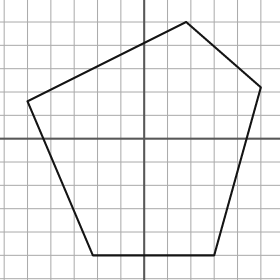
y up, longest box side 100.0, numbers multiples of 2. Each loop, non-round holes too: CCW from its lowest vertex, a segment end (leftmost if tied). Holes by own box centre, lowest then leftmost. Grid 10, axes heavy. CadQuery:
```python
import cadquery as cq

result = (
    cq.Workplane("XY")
    .moveTo(-22.0, -50.0)
    .lineTo(30.0, -50.0)
    .lineTo(50.0, 22.0)
    .lineTo(18.0, 50.0)
    .lineTo(-50.0, 16.0)
    .close()
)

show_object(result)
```